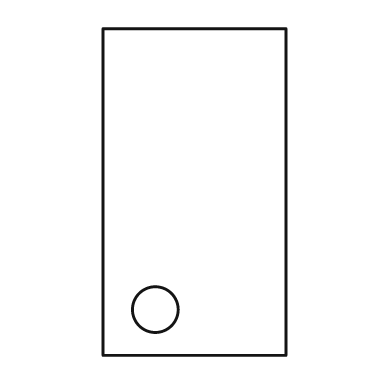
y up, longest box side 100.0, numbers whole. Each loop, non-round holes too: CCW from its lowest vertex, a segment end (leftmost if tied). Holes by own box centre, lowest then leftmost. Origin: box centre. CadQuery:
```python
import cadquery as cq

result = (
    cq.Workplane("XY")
    .moveTo(-28.0, -50.0)
    .lineTo(28.0, -50.0)
    .lineTo(28.0, 50.0)
    .lineTo(-28.0, 50.0)
    .close()
    .moveTo(-12.0, -36.0)
    .circle(7.0)
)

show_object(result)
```